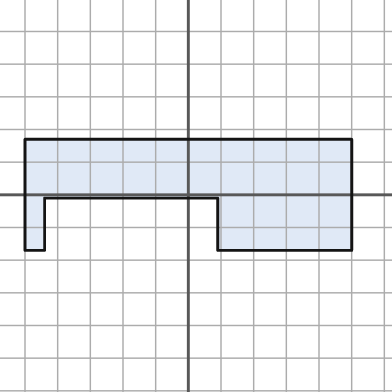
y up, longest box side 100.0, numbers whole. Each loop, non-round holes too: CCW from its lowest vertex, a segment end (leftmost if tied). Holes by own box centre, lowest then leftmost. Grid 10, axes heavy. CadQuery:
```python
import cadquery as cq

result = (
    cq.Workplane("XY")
    .moveTo(-50.0, -17.0)
    .lineTo(-44.0, -17.0)
    .lineTo(-44.0, -1.0)
    .lineTo(9.0, -1.0)
    .lineTo(9.0, -17.0)
    .lineTo(50.0, -17.0)
    .lineTo(50.0, 17.0)
    .lineTo(-50.0, 17.0)
    .close()
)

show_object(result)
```